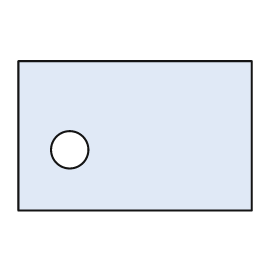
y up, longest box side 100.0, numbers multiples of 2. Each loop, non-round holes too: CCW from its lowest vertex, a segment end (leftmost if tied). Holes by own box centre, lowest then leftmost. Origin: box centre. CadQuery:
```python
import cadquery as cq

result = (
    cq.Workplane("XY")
    .moveTo(-50.0, -32.0)
    .lineTo(50.0, -32.0)
    .lineTo(50.0, 32.0)
    .lineTo(-50.0, 32.0)
    .close()
    .moveTo(-28.0, -6.0)
    .circle(8.0)
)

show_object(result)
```